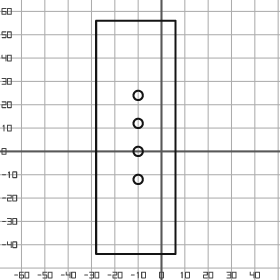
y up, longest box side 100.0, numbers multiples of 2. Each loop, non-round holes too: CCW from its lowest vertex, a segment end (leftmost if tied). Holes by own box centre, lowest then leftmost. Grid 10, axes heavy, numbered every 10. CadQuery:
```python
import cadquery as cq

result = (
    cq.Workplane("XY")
    .moveTo(-28.0, -44.0)
    .lineTo(6.0, -44.0)
    .lineTo(6.0, 56.0)
    .lineTo(-28.0, 56.0)
    .close()
    .moveTo(-10.0, -12.0)
    .circle(2.0)
    .moveTo(-10.0, 0.0)
    .circle(2.0)
    .moveTo(-10.0, 12.0)
    .circle(2.0)
    .moveTo(-10.0, 24.0)
    .circle(2.0)
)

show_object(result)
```